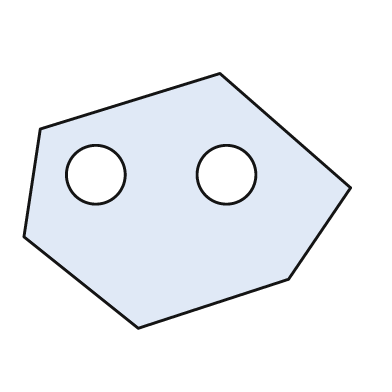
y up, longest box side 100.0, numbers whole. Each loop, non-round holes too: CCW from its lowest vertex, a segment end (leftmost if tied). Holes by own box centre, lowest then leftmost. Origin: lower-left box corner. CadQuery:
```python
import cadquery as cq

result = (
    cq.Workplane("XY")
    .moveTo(35.0, 0.0)
    .lineTo(81.0, 15.0)
    .lineTo(100.0, 43.0)
    .lineTo(60.0, 78.0)
    .lineTo(5.0, 61.0)
    .lineTo(0.0, 28.0)
    .close()
    .moveTo(22.0, 47.0)
    .circle(9.0)
    .moveTo(62.0, 47.0)
    .circle(9.0)
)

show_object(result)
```